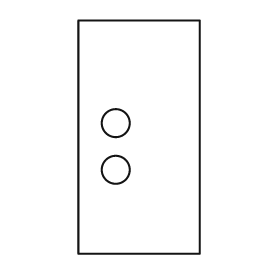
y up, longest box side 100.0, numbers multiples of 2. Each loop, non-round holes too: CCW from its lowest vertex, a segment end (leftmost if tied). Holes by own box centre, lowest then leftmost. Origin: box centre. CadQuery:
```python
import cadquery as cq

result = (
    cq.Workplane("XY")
    .moveTo(-26.0, -50.0)
    .lineTo(26.0, -50.0)
    .lineTo(26.0, 50.0)
    .lineTo(-26.0, 50.0)
    .close()
    .moveTo(-10.0, -14.0)
    .circle(6.0)
    .moveTo(-10.0, 6.0)
    .circle(6.0)
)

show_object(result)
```